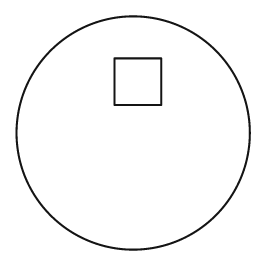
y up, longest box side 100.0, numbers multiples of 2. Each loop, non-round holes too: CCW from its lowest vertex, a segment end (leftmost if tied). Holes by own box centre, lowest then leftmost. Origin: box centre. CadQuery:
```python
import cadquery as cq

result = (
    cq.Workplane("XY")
    .moveTo(0.0, 0.0)
    .circle(50.0)
    .moveTo(-8.0, 12.0)
    .lineTo(12.0, 12.0)
    .lineTo(12.0, 32.0)
    .lineTo(-8.0, 32.0)
    .close()
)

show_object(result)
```